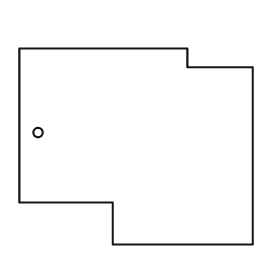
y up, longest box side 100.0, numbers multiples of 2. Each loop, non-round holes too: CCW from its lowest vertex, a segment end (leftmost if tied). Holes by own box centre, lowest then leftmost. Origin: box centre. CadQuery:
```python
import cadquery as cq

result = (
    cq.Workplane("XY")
    .moveTo(-10.0, -42.0)
    .lineTo(50.0, -42.0)
    .lineTo(50.0, 34.0)
    .lineTo(22.0, 34.0)
    .lineTo(22.0, 42.0)
    .lineTo(-50.0, 42.0)
    .lineTo(-50.0, -24.0)
    .lineTo(-10.0, -24.0)
    .close()
    .moveTo(-42.0, 6.0)
    .circle(2.0)
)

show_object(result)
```